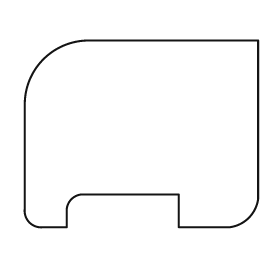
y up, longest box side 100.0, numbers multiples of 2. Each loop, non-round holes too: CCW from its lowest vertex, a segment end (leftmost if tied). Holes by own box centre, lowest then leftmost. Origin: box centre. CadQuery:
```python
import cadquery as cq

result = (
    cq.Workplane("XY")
    .moveTo(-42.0, -40.0)
    .lineTo(-32.0, -40.0)
    .lineTo(-32.0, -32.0)
    .threePointArc((-30.0, -28.0), (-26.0, -26.0))
    .lineTo(16.0, -26.0)
    .lineTo(16.0, -40.0)
    .lineTo(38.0, -40.0)
    .threePointArc((46.0, -36.0), (50.0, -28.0))
    .lineTo(50.0, 40.0)
    .lineTo(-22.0, 40.0)
    .threePointArc((-42.0, 32.0), (-50.0, 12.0))
    .lineTo(-50.0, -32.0)
    .threePointArc((-48.0, -38.0), (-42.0, -40.0))
    .close()
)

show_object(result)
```